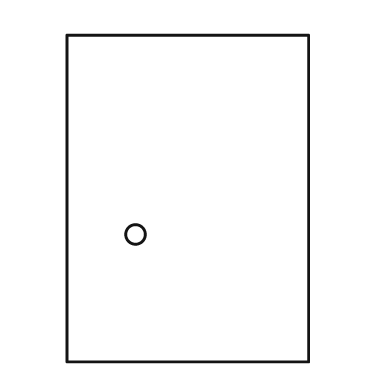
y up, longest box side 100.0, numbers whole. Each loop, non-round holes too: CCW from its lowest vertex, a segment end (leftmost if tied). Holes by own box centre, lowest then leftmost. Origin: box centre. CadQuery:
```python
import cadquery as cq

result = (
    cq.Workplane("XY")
    .moveTo(-37.0, -50.0)
    .lineTo(37.0, -50.0)
    .lineTo(37.0, 50.0)
    .lineTo(-37.0, 50.0)
    .close()
    .moveTo(-16.0, -11.0)
    .circle(3.0)
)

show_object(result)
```